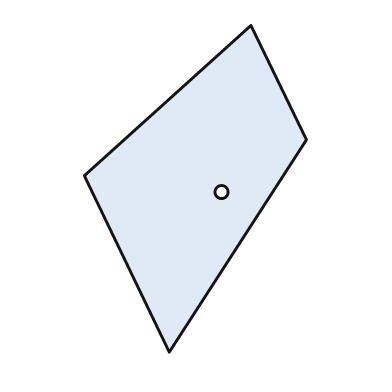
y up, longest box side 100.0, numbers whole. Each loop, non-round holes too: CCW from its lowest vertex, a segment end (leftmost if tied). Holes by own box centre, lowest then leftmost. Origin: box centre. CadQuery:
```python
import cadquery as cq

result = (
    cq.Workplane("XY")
    .moveTo(-8.0, -50.0)
    .lineTo(34.0, 15.0)
    .lineTo(17.0, 50.0)
    .lineTo(-34.0, 4.0)
    .close()
    .moveTo(8.0, -1.0)
    .circle(2.0)
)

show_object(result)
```